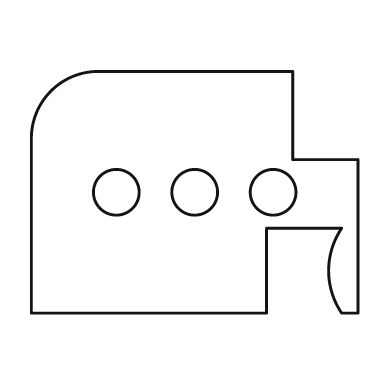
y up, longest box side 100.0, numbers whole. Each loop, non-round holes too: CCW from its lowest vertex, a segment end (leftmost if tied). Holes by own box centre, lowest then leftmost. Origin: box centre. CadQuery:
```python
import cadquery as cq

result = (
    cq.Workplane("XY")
    .moveTo(-50.0, -37.0)
    .lineTo(22.0, -37.0)
    .lineTo(22.0, -11.0)
    .lineTo(45.0, -11.0)
    .threePointArc((41.0, -24.0), (45.0, -37.0))
    .lineTo(50.0, -37.0)
    .lineTo(50.0, 10.0)
    .lineTo(30.0, 10.0)
    .lineTo(30.0, 37.0)
    .lineTo(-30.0, 37.0)
    .threePointArc((-44.0, 31.0), (-50.0, 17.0))
    .close()
    .moveTo(-24.0, 0.0)
    .circle(7.0)
    .moveTo(0.0, 0.0)
    .circle(7.0)
    .moveTo(24.0, 0.0)
    .circle(7.0)
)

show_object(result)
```